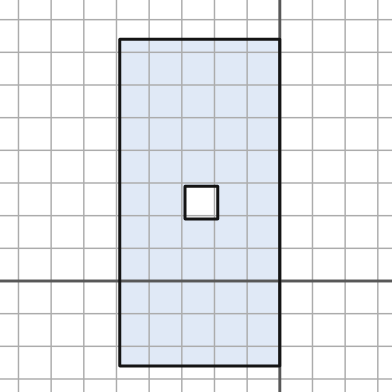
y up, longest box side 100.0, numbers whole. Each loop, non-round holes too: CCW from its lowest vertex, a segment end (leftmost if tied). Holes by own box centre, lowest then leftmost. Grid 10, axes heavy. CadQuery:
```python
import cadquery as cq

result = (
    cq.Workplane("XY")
    .moveTo(-49.0, -26.0)
    .lineTo(0.0, -26.0)
    .lineTo(0.0, 74.0)
    .lineTo(-49.0, 74.0)
    .close()
    .moveTo(-29.0, 19.0)
    .lineTo(-19.0, 19.0)
    .lineTo(-19.0, 29.0)
    .lineTo(-29.0, 29.0)
    .close()
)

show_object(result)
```